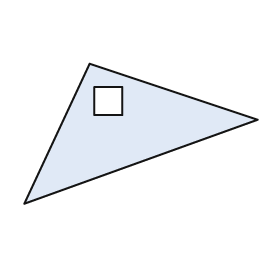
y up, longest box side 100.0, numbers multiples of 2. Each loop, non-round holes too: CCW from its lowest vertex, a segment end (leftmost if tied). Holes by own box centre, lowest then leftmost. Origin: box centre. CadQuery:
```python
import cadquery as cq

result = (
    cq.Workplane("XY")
    .moveTo(-50.0, -30.0)
    .lineTo(50.0, 6.0)
    .lineTo(-22.0, 30.0)
    .close()
    .moveTo(-20.0, 8.0)
    .lineTo(-8.0, 8.0)
    .lineTo(-8.0, 20.0)
    .lineTo(-20.0, 20.0)
    .close()
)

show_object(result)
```